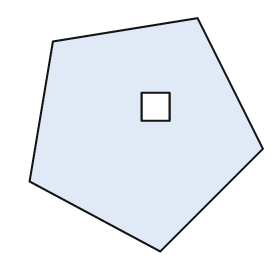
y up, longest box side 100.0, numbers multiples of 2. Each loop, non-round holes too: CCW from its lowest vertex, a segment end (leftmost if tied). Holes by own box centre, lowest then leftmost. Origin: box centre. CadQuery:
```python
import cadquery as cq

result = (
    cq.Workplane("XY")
    .moveTo(6.0, -50.0)
    .lineTo(50.0, -6.0)
    .lineTo(22.0, 50.0)
    .lineTo(-40.0, 40.0)
    .lineTo(-50.0, -20.0)
    .close()
    .moveTo(-2.0, 6.0)
    .lineTo(10.0, 6.0)
    .lineTo(10.0, 18.0)
    .lineTo(-2.0, 18.0)
    .close()
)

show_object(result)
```